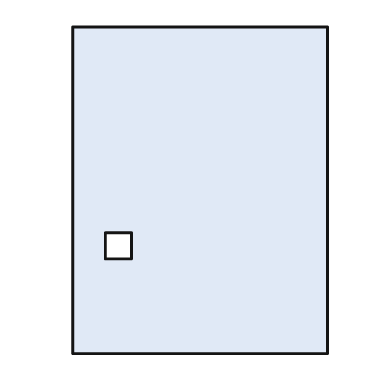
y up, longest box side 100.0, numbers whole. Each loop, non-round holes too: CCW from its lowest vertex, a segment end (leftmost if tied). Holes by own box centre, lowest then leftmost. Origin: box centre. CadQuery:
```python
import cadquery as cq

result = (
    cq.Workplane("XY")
    .moveTo(-39.0, -50.0)
    .lineTo(39.0, -50.0)
    .lineTo(39.0, 50.0)
    .lineTo(-39.0, 50.0)
    .close()
    .moveTo(-29.0, -21.0)
    .lineTo(-21.0, -21.0)
    .lineTo(-21.0, -13.0)
    .lineTo(-29.0, -13.0)
    .close()
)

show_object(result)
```